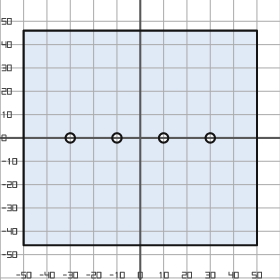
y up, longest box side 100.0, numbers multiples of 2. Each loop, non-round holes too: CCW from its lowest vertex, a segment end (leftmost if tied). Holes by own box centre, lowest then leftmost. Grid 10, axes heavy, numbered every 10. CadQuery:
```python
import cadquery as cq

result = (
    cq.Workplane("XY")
    .moveTo(-50.0, -46.0)
    .lineTo(50.0, -46.0)
    .lineTo(50.0, 46.0)
    .lineTo(-50.0, 46.0)
    .close()
    .moveTo(-30.0, 0.0)
    .circle(2.0)
    .moveTo(-10.0, 0.0)
    .circle(2.0)
    .moveTo(10.0, 0.0)
    .circle(2.0)
    .moveTo(30.0, 0.0)
    .circle(2.0)
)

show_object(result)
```